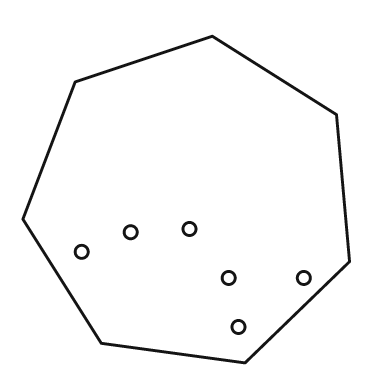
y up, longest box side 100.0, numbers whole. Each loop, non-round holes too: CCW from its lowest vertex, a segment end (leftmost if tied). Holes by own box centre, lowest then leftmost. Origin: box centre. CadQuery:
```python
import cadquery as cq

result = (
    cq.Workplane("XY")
    .moveTo(18.0, -50.0)
    .lineTo(50.0, -19.0)
    .lineTo(46.0, 26.0)
    .lineTo(8.0, 50.0)
    .lineTo(-34.0, 36.0)
    .lineTo(-50.0, -6.0)
    .lineTo(-26.0, -44.0)
    .close()
    .moveTo(16.0, -39.0)
    .circle(2.0)
    .moveTo(13.0, -24.0)
    .circle(2.0)
    .moveTo(36.0, -24.0)
    .circle(2.0)
    .moveTo(-32.0, -16.0)
    .circle(2.0)
    .moveTo(-17.0, -10.0)
    .circle(2.0)
    .moveTo(1.0, -9.0)
    .circle(2.0)
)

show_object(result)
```